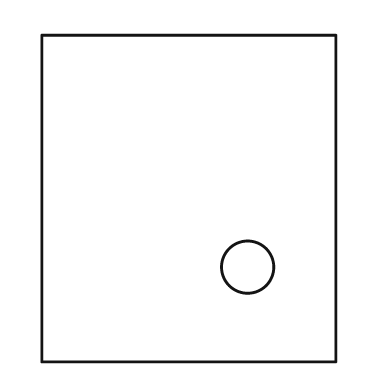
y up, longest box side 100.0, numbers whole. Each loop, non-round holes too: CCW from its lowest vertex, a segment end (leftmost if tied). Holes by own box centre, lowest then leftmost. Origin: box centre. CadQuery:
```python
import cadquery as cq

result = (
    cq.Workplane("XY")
    .moveTo(-45.0, -50.0)
    .lineTo(45.0, -50.0)
    .lineTo(45.0, 50.0)
    .lineTo(-45.0, 50.0)
    .close()
    .moveTo(18.0, -21.0)
    .circle(8.0)
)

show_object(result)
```